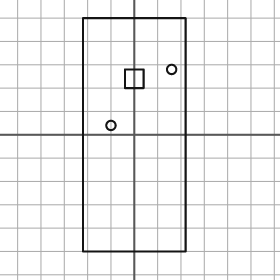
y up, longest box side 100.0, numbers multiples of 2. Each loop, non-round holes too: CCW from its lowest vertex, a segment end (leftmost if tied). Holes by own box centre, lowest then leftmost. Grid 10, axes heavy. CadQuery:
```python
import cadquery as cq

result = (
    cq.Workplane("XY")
    .moveTo(-22.0, -50.0)
    .lineTo(22.0, -50.0)
    .lineTo(22.0, 50.0)
    .lineTo(-22.0, 50.0)
    .close()
    .moveTo(-10.0, 4.0)
    .circle(2.0)
    .moveTo(-4.0, 20.0)
    .lineTo(4.0, 20.0)
    .lineTo(4.0, 28.0)
    .lineTo(-4.0, 28.0)
    .close()
    .moveTo(16.0, 28.0)
    .circle(2.0)
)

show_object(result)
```